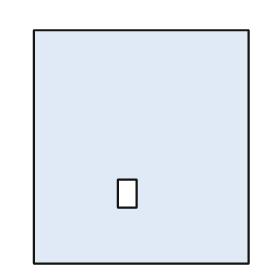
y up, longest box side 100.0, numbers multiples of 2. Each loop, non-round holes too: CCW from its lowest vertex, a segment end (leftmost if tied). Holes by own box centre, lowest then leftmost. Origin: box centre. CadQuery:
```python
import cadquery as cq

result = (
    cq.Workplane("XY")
    .moveTo(-46.0, -50.0)
    .lineTo(46.0, -50.0)
    .lineTo(46.0, 50.0)
    .lineTo(-46.0, 50.0)
    .close()
    .moveTo(-10.0, -26.0)
    .lineTo(-2.0, -26.0)
    .lineTo(-2.0, -14.0)
    .lineTo(-10.0, -14.0)
    .close()
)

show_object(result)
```